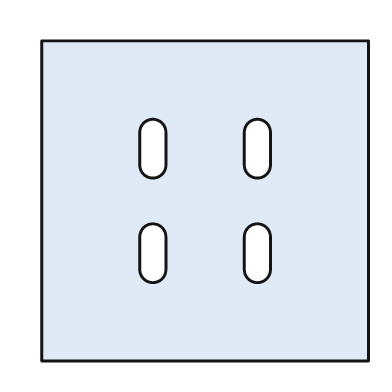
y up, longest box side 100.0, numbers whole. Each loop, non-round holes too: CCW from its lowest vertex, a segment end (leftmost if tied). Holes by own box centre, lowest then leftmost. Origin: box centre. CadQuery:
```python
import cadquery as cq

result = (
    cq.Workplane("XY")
    .moveTo(-50.0, -49.0)
    .lineTo(50.0, -49.0)
    .lineTo(50.0, 49.0)
    .lineTo(-50.0, 49.0)
    .close()
    .moveTo(-20.0, -21.0)
    .threePointArc((-16.0, -25.0), (-12.0, -21.0))
    .lineTo(-12.0, -11.0)
    .threePointArc((-16.0, -7.0), (-20.0, -11.0))
    .close()
    .moveTo(12.0, -21.0)
    .threePointArc((16.0, -25.0), (20.0, -21.0))
    .lineTo(20.0, -11.0)
    .threePointArc((16.0, -7.0), (12.0, -11.0))
    .close()
    .moveTo(-20.0, 11.0)
    .threePointArc((-16.0, 7.0), (-12.0, 11.0))
    .lineTo(-12.0, 21.0)
    .threePointArc((-16.0, 25.0), (-20.0, 21.0))
    .close()
    .moveTo(12.0, 11.0)
    .threePointArc((16.0, 7.0), (20.0, 11.0))
    .lineTo(20.0, 21.0)
    .threePointArc((16.0, 25.0), (12.0, 21.0))
    .close()
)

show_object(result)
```